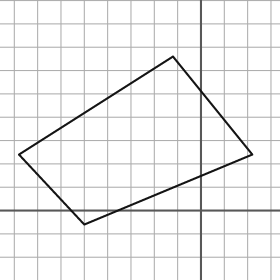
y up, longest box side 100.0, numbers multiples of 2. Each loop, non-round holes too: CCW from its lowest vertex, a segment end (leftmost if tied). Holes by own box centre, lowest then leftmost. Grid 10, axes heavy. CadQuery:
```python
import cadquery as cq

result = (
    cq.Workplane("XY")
    .moveTo(-50.0, -6.0)
    .lineTo(22.0, 24.0)
    .lineTo(-12.0, 66.0)
    .lineTo(-78.0, 24.0)
    .close()
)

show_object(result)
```